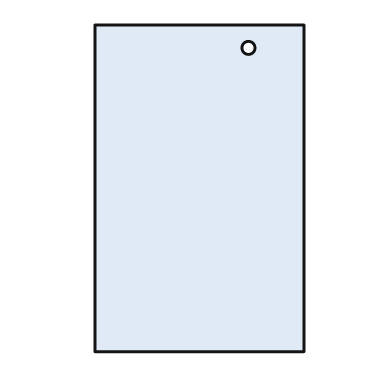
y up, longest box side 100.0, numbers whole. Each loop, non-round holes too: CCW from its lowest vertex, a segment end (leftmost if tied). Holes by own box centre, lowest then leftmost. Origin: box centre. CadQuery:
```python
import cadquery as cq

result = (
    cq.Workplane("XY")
    .moveTo(-32.0, -50.0)
    .lineTo(32.0, -50.0)
    .lineTo(32.0, 50.0)
    .lineTo(-32.0, 50.0)
    .close()
    .moveTo(15.0, 43.0)
    .circle(2.0)
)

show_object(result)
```